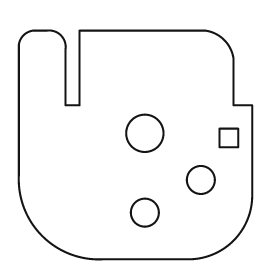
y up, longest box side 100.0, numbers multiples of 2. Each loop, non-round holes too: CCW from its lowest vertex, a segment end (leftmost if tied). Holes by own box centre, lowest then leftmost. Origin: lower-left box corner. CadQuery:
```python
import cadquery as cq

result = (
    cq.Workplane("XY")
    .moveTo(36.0, 0.0)
    .lineTo(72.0, 0.0)
    .threePointArc((92.0, 8.0), (100.0, 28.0))
    .lineTo(100.0, 66.0)
    .lineTo(92.0, 66.0)
    .lineTo(92.0, 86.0)
    .threePointArc((88.0, 94.0), (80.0, 98.0))
    .lineTo(26.0, 98.0)
    .lineTo(26.0, 66.0)
    .lineTo(20.0, 66.0)
    .lineTo(20.0, 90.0)
    .threePointArc((18.0, 96.0), (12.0, 98.0))
    .lineTo(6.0, 98.0)
    .threePointArc((2.0, 96.0), (0.0, 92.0))
    .lineTo(0.0, 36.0)
    .threePointArc((10.0, 10.0), (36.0, 0.0))
    .close()
    .moveTo(54.0, 20.0)
    .circle(6.0)
    .moveTo(78.0, 34.0)
    .circle(6.0)
    .moveTo(86.0, 48.0)
    .lineTo(94.0, 48.0)
    .lineTo(94.0, 56.0)
    .lineTo(86.0, 56.0)
    .close()
    .moveTo(54.0, 54.0)
    .circle(8.0)
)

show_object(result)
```